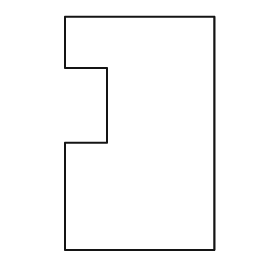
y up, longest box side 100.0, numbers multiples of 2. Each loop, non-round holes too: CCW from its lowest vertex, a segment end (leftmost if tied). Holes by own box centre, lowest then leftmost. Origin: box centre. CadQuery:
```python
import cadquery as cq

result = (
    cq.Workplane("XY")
    .moveTo(-32.0, -50.0)
    .lineTo(32.0, -50.0)
    .lineTo(32.0, 50.0)
    .lineTo(-32.0, 50.0)
    .lineTo(-32.0, 28.0)
    .lineTo(-14.0, 28.0)
    .lineTo(-14.0, -4.0)
    .lineTo(-32.0, -4.0)
    .close()
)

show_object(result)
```